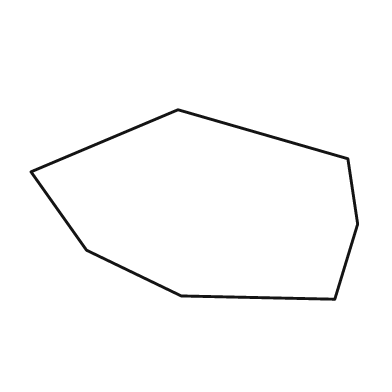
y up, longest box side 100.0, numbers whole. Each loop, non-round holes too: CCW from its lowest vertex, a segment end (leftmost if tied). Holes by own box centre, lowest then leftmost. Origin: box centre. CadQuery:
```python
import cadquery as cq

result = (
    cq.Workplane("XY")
    .moveTo(43.0, -29.0)
    .lineTo(50.0, -6.0)
    .lineTo(47.0, 14.0)
    .lineTo(-5.0, 29.0)
    .lineTo(-50.0, 10.0)
    .lineTo(-33.0, -14.0)
    .lineTo(-4.0, -28.0)
    .close()
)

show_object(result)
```